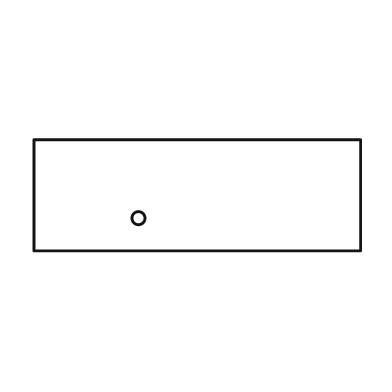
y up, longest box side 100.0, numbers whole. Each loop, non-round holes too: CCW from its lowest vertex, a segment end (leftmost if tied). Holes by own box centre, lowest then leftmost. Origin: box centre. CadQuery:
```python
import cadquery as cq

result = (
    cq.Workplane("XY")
    .moveTo(-50.0, -17.0)
    .lineTo(50.0, -17.0)
    .lineTo(50.0, 17.0)
    .lineTo(-50.0, 17.0)
    .close()
    .moveTo(-18.0, -7.0)
    .circle(2.0)
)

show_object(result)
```